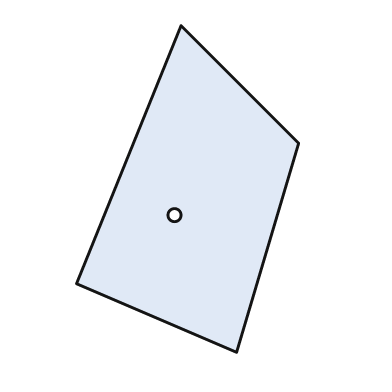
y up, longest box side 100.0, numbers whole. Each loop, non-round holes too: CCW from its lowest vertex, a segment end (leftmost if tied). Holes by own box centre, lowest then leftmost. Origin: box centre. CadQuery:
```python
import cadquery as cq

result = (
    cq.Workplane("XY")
    .moveTo(15.0, -50.0)
    .lineTo(34.0, 14.0)
    .lineTo(-2.0, 50.0)
    .lineTo(-34.0, -29.0)
    .close()
    .moveTo(-4.0, -8.0)
    .circle(2.0)
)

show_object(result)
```